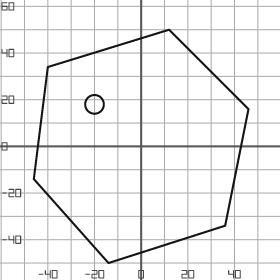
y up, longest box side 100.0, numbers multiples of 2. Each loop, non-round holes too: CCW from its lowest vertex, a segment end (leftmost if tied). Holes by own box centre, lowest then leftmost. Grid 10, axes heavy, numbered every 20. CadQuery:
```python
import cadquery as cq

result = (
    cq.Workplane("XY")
    .moveTo(-14.0, -50.0)
    .lineTo(36.0, -34.0)
    .lineTo(46.0, 16.0)
    .lineTo(12.0, 50.0)
    .lineTo(-40.0, 34.0)
    .lineTo(-46.0, -14.0)
    .close()
    .moveTo(-20.0, 18.0)
    .circle(4.0)
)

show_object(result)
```